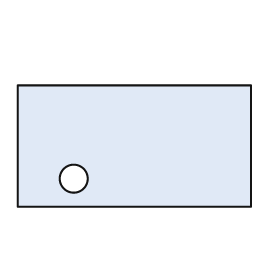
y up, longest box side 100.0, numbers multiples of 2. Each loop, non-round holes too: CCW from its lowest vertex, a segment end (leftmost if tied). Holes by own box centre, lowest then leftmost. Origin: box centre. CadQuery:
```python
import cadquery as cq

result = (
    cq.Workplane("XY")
    .moveTo(-50.0, -26.0)
    .lineTo(50.0, -26.0)
    .lineTo(50.0, 26.0)
    .lineTo(-50.0, 26.0)
    .close()
    .moveTo(-26.0, -14.0)
    .circle(6.0)
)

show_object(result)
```